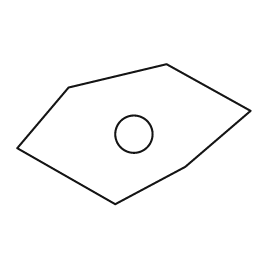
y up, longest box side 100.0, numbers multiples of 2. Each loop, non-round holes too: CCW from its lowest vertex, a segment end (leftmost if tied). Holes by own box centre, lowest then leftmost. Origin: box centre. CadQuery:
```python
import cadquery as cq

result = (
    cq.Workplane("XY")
    .moveTo(-8.0, -30.0)
    .lineTo(22.0, -14.0)
    .lineTo(50.0, 10.0)
    .lineTo(14.0, 30.0)
    .lineTo(-28.0, 20.0)
    .lineTo(-50.0, -6.0)
    .close()
    .moveTo(0.0, 0.0)
    .circle(8.0)
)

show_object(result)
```